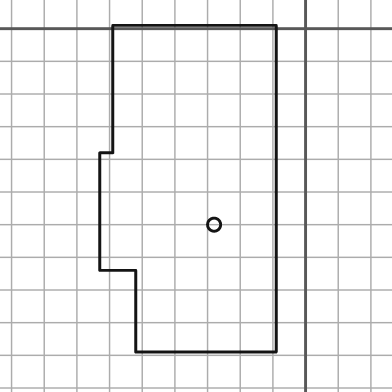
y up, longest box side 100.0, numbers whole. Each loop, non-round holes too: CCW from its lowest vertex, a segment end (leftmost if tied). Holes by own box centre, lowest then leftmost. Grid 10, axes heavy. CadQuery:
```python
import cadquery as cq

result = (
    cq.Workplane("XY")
    .moveTo(-52.0, -99.0)
    .lineTo(-9.0, -99.0)
    .lineTo(-9.0, 1.0)
    .lineTo(-59.0, 1.0)
    .lineTo(-59.0, -38.0)
    .lineTo(-63.0, -38.0)
    .lineTo(-63.0, -74.0)
    .lineTo(-52.0, -74.0)
    .close()
    .moveTo(-28.0, -60.0)
    .circle(2.0)
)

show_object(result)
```